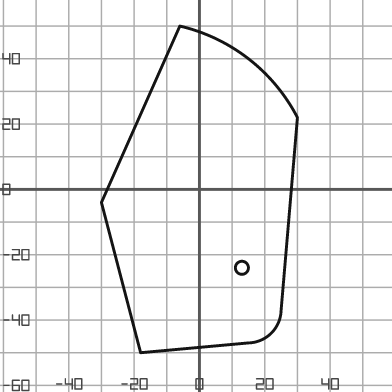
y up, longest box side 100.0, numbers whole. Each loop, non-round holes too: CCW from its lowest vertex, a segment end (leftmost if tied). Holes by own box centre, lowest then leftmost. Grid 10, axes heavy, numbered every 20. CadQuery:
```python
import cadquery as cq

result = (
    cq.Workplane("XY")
    .moveTo(-18.0, -50.0)
    .lineTo(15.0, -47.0)
    .threePointArc((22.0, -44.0), (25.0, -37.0))
    .lineTo(30.0, 22.0)
    .threePointArc((15.0, 40.0), (-6.0, 50.0))
    .lineTo(-30.0, -4.0)
    .close()
    .moveTo(13.0, -24.0)
    .circle(2.0)
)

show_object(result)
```